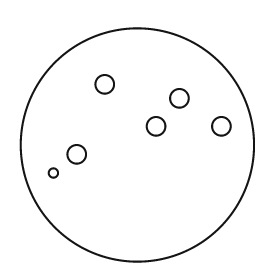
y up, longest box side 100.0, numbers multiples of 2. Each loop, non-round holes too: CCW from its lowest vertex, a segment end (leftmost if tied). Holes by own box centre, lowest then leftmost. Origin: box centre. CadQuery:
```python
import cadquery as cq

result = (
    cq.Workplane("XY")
    .moveTo(0.0, 0.0)
    .circle(50.0)
    .moveTo(-36.0, -12.0)
    .circle(2.0)
    .moveTo(-26.0, -4.0)
    .circle(4.0)
    .moveTo(8.0, 8.0)
    .circle(4.0)
    .moveTo(36.0, 8.0)
    .circle(4.0)
    .moveTo(18.0, 20.0)
    .circle(4.0)
    .moveTo(-14.0, 26.0)
    .circle(4.0)
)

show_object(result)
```